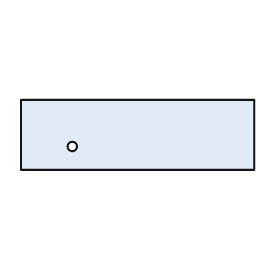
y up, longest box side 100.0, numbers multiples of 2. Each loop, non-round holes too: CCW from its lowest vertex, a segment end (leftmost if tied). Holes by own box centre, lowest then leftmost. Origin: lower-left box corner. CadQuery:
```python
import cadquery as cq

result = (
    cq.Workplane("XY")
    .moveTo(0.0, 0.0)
    .lineTo(100.0, 0.0)
    .lineTo(100.0, 30.0)
    .lineTo(0.0, 30.0)
    .close()
    .moveTo(22.0, 10.0)
    .circle(2.0)
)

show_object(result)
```